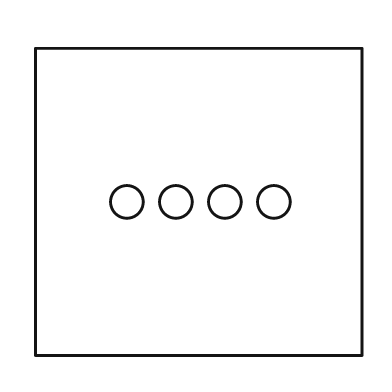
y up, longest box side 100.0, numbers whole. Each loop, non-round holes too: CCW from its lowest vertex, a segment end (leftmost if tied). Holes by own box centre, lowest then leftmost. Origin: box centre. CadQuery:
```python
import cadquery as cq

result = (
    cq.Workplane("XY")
    .moveTo(-50.0, -47.0)
    .lineTo(50.0, -47.0)
    .lineTo(50.0, 47.0)
    .lineTo(-50.0, 47.0)
    .close()
    .moveTo(-22.0, 0.0)
    .circle(5.0)
    .moveTo(-7.0, 0.0)
    .circle(5.0)
    .moveTo(8.0, 0.0)
    .circle(5.0)
    .moveTo(23.0, 0.0)
    .circle(5.0)
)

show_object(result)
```